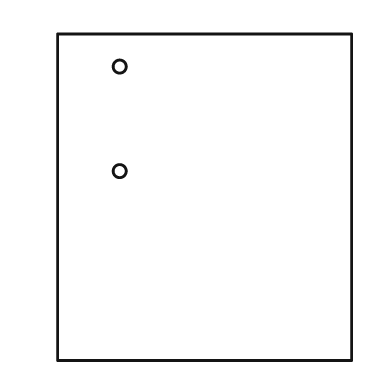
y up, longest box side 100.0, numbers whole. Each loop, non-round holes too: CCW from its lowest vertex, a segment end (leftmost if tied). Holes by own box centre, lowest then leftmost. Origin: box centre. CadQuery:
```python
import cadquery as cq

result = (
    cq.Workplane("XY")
    .moveTo(-45.0, -50.0)
    .lineTo(45.0, -50.0)
    .lineTo(45.0, 50.0)
    .lineTo(-45.0, 50.0)
    .close()
    .moveTo(-26.0, 8.0)
    .circle(2.0)
    .moveTo(-26.0, 40.0)
    .circle(2.0)
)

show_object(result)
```